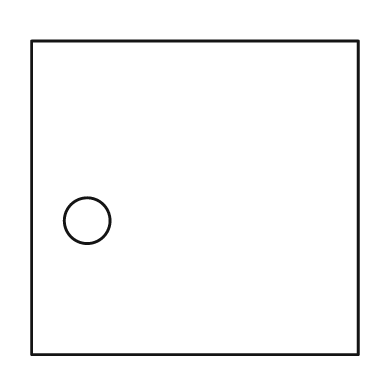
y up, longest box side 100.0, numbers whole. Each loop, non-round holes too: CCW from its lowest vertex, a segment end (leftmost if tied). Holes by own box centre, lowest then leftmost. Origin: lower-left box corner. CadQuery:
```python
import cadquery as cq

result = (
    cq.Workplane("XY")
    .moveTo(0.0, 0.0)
    .lineTo(100.0, 0.0)
    .lineTo(100.0, 96.0)
    .lineTo(0.0, 96.0)
    .close()
    .moveTo(17.0, 41.0)
    .circle(7.0)
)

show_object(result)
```